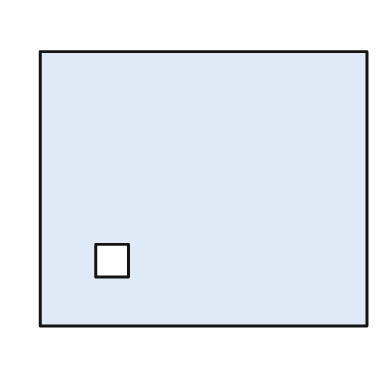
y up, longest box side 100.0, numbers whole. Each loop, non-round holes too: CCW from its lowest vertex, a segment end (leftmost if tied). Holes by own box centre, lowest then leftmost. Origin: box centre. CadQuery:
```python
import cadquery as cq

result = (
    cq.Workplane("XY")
    .moveTo(-50.0, -42.0)
    .lineTo(50.0, -42.0)
    .lineTo(50.0, 42.0)
    .lineTo(-50.0, 42.0)
    .close()
    .moveTo(-33.0, -27.0)
    .lineTo(-23.0, -27.0)
    .lineTo(-23.0, -17.0)
    .lineTo(-33.0, -17.0)
    .close()
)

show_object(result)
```